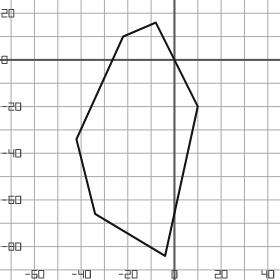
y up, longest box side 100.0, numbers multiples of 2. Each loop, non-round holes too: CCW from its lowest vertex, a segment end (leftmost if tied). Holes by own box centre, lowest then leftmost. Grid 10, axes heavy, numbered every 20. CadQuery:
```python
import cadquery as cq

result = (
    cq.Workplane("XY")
    .moveTo(-4.0, -84.0)
    .lineTo(10.0, -20.0)
    .lineTo(-8.0, 16.0)
    .lineTo(-22.0, 10.0)
    .lineTo(-42.0, -34.0)
    .lineTo(-34.0, -66.0)
    .close()
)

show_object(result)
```